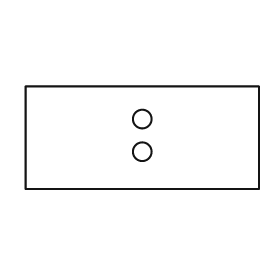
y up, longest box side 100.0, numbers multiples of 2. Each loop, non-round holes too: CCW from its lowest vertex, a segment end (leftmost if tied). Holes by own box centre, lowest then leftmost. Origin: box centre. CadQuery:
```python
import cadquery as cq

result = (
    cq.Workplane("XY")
    .moveTo(-50.0, -22.0)
    .lineTo(50.0, -22.0)
    .lineTo(50.0, 22.0)
    .lineTo(-50.0, 22.0)
    .close()
    .moveTo(0.0, -6.0)
    .circle(4.0)
    .moveTo(0.0, 8.0)
    .circle(4.0)
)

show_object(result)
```